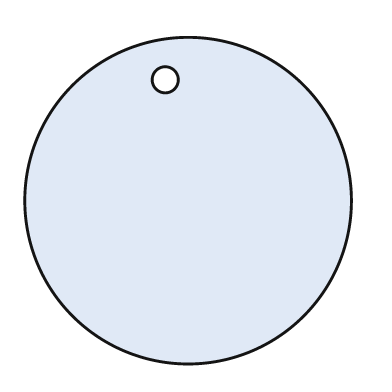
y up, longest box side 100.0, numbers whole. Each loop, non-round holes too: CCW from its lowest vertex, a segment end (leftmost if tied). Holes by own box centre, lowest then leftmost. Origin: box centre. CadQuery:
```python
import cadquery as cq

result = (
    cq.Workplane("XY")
    .moveTo(0.0, 0.0)
    .circle(50.0)
    .moveTo(-7.0, 37.0)
    .circle(4.0)
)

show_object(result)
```